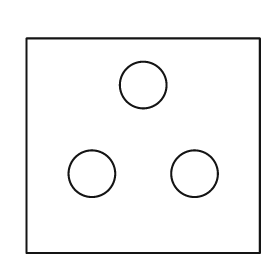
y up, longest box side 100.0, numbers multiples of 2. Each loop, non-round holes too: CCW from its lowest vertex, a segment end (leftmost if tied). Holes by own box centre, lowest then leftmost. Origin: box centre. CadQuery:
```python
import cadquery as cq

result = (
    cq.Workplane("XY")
    .moveTo(-50.0, -46.0)
    .lineTo(50.0, -46.0)
    .lineTo(50.0, 46.0)
    .lineTo(-50.0, 46.0)
    .close()
    .moveTo(-22.0, -12.0)
    .circle(10.0)
    .moveTo(22.0, -12.0)
    .circle(10.0)
    .moveTo(0.0, 26.0)
    .circle(10.0)
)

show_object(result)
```